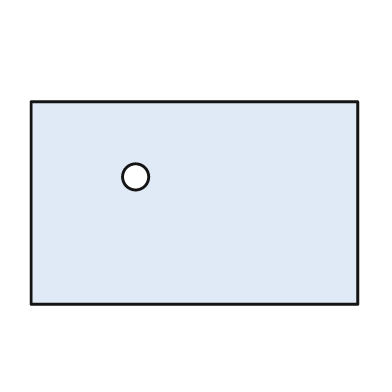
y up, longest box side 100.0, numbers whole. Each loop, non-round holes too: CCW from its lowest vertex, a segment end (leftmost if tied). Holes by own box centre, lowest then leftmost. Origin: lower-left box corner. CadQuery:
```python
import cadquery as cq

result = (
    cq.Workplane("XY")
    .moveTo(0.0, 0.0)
    .lineTo(100.0, 0.0)
    .lineTo(100.0, 62.0)
    .lineTo(0.0, 62.0)
    .close()
    .moveTo(32.0, 39.0)
    .circle(4.0)
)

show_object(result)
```